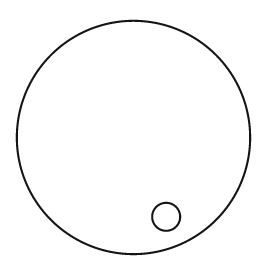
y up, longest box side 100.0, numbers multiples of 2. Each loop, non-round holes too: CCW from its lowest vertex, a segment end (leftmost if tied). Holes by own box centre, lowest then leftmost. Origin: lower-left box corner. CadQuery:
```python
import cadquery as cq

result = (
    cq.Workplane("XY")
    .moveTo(50.0, 50.0)
    .circle(50.0)
    .moveTo(64.0, 16.0)
    .circle(6.0)
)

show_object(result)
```